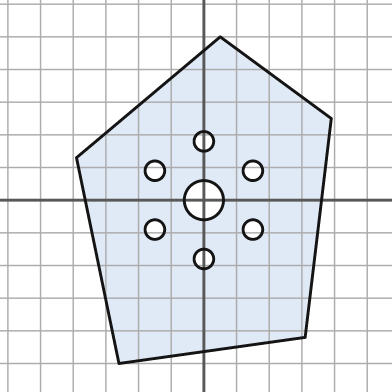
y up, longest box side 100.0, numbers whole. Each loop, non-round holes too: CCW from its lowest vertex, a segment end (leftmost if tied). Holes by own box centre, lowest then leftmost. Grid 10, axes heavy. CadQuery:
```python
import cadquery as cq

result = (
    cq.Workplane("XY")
    .moveTo(-26.0, -50.0)
    .lineTo(31.0, -42.0)
    .lineTo(39.0, 25.0)
    .lineTo(5.0, 50.0)
    .lineTo(-39.0, 13.0)
    .close()
    .moveTo(0.0, -18.0)
    .circle(3.0)
    .moveTo(-15.0, -9.0)
    .circle(3.0)
    .moveTo(15.0, -9.0)
    .circle(3.0)
    .moveTo(0.0, 0.0)
    .circle(6.0)
    .moveTo(-15.0, 9.0)
    .circle(3.0)
    .moveTo(15.0, 9.0)
    .circle(3.0)
    .moveTo(0.0, 18.0)
    .circle(3.0)
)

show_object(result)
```